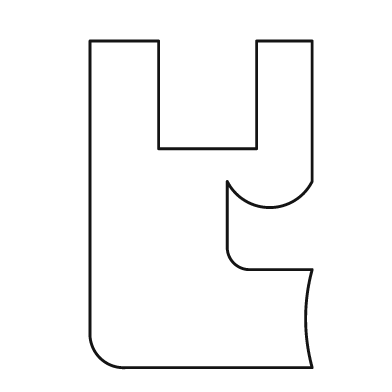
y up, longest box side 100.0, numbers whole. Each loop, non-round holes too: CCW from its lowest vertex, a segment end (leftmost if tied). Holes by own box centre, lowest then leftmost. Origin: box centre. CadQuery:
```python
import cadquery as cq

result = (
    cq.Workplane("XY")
    .moveTo(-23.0, -50.0)
    .lineTo(34.0, -50.0)
    .threePointArc((32.0, -35.0), (34.0, -20.0))
    .lineTo(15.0, -20.0)
    .threePointArc((10.0, -18.0), (8.0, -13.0))
    .lineTo(8.0, 7.0)
    .threePointArc((21.0, -1.0), (34.0, 7.0))
    .lineTo(34.0, 50.0)
    .lineTo(17.0, 50.0)
    .lineTo(17.0, 17.0)
    .lineTo(-13.0, 17.0)
    .lineTo(-13.0, 50.0)
    .lineTo(-34.0, 50.0)
    .lineTo(-34.0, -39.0)
    .threePointArc((-31.0, -47.0), (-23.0, -50.0))
    .close()
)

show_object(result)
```